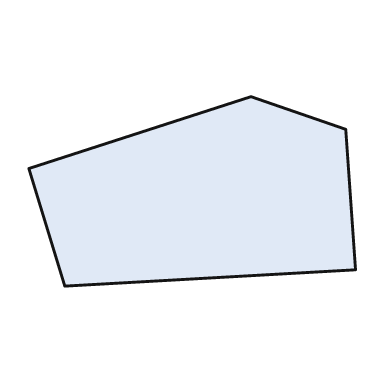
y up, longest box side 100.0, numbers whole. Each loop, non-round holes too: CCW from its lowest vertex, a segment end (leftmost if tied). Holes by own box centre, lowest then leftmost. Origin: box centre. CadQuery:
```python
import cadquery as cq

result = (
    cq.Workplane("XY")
    .moveTo(-39.0, -29.0)
    .lineTo(50.0, -24.0)
    .lineTo(47.0, 19.0)
    .lineTo(18.0, 29.0)
    .lineTo(-50.0, 7.0)
    .close()
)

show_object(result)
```